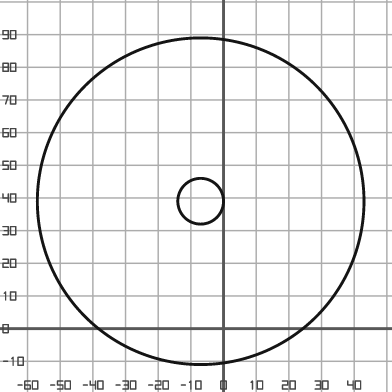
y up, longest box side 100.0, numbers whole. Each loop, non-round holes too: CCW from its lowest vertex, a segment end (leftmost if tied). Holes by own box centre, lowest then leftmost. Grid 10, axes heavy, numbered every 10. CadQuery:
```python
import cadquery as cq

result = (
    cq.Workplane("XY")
    .moveTo(-7.0, 39.0)
    .circle(50.0)
    .moveTo(-7.0, 39.0)
    .circle(7.0)
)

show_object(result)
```